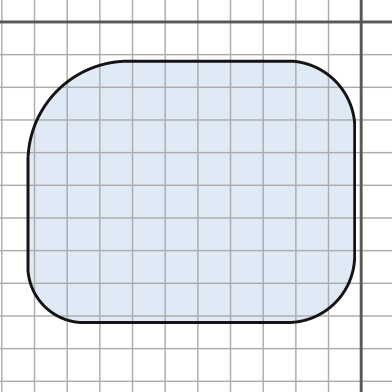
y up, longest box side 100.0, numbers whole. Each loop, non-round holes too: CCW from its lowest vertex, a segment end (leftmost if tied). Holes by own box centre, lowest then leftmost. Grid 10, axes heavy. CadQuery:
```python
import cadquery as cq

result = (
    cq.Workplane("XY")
    .moveTo(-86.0, -92.0)
    .lineTo(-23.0, -92.0)
    .threePointArc((-8.0, -86.0), (-2.0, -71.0))
    .lineTo(-2.0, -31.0)
    .threePointArc((-8.0, -18.0), (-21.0, -12.0))
    .lineTo(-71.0, -12.0)
    .threePointArc((-93.0, -21.0), (-102.0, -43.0))
    .lineTo(-102.0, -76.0)
    .threePointArc((-97.0, -87.0), (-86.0, -92.0))
    .close()
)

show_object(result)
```